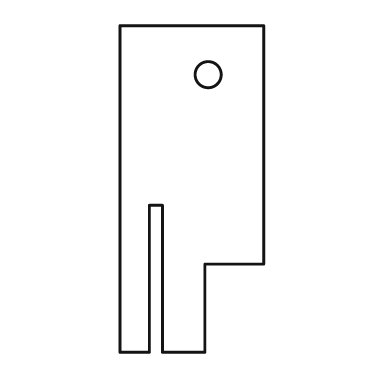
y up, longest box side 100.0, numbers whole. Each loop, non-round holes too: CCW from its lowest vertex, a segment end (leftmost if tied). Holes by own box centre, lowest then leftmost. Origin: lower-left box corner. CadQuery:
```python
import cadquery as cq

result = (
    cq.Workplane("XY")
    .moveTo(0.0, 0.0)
    .lineTo(9.0, 0.0)
    .lineTo(9.0, 45.0)
    .lineTo(13.0, 45.0)
    .lineTo(13.0, 0.0)
    .lineTo(26.0, 0.0)
    .lineTo(26.0, 27.0)
    .lineTo(44.0, 27.0)
    .lineTo(44.0, 100.0)
    .lineTo(0.0, 100.0)
    .close()
    .moveTo(27.0, 85.0)
    .circle(4.0)
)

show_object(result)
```